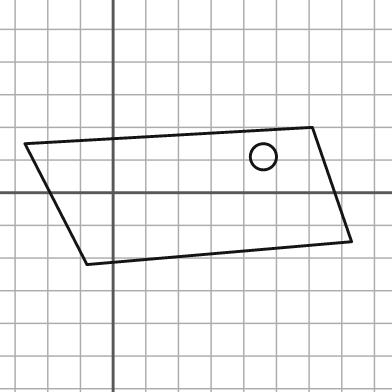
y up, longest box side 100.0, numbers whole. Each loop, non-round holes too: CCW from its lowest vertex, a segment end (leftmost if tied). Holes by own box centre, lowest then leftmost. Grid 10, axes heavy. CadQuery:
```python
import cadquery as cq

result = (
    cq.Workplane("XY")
    .moveTo(-8.0, -22.0)
    .lineTo(73.0, -15.0)
    .lineTo(61.0, 20.0)
    .lineTo(-27.0, 15.0)
    .close()
    .moveTo(46.0, 11.0)
    .circle(4.0)
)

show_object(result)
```